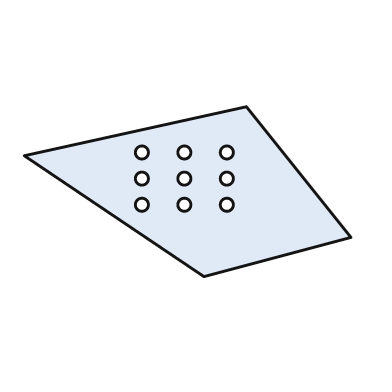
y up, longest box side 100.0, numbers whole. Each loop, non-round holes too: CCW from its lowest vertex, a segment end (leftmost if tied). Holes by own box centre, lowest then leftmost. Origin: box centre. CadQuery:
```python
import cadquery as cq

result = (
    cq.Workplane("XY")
    .moveTo(5.0, -26.0)
    .lineTo(50.0, -14.0)
    .lineTo(18.0, 26.0)
    .lineTo(-50.0, 11.0)
    .close()
    .moveTo(-14.0, -4.0)
    .circle(2.0)
    .moveTo(-1.0, -4.0)
    .circle(2.0)
    .moveTo(12.0, -4.0)
    .circle(2.0)
    .moveTo(-14.0, 4.0)
    .circle(2.0)
    .moveTo(-1.0, 4.0)
    .circle(2.0)
    .moveTo(12.0, 4.0)
    .circle(2.0)
    .moveTo(-14.0, 12.0)
    .circle(2.0)
    .moveTo(-1.0, 12.0)
    .circle(2.0)
    .moveTo(12.0, 12.0)
    .circle(2.0)
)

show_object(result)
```